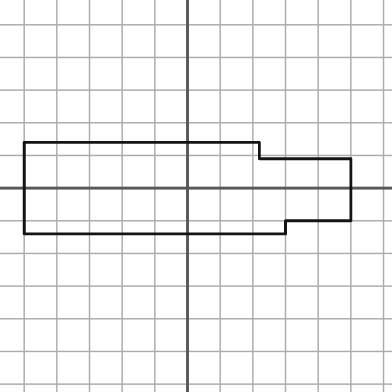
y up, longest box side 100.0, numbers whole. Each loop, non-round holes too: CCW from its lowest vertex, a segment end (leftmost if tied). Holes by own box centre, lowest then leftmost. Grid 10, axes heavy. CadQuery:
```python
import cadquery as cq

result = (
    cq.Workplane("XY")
    .moveTo(-50.0, -14.0)
    .lineTo(30.0, -14.0)
    .lineTo(30.0, -10.0)
    .lineTo(50.0, -10.0)
    .lineTo(50.0, 9.0)
    .lineTo(22.0, 9.0)
    .lineTo(22.0, 14.0)
    .lineTo(-50.0, 14.0)
    .close()
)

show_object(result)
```